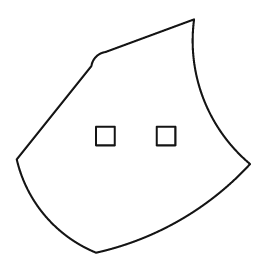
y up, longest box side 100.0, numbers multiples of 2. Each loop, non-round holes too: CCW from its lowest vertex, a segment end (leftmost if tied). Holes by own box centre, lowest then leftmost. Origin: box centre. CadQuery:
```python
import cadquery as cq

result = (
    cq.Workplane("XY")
    .moveTo(-16.0, -50.0)
    .threePointArc((20.0, -36.0), (50.0, -12.0))
    .threePointArc((30.0, 16.0), (26.0, 50.0))
    .lineTo(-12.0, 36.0)
    .threePointArc((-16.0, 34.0), (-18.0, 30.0))
    .lineTo(-50.0, -10.0)
    .threePointArc((-38.0, -34.0), (-16.0, -50.0))
    .close()
    .moveTo(-16.0, -4.0)
    .lineTo(-8.0, -4.0)
    .lineTo(-8.0, 4.0)
    .lineTo(-16.0, 4.0)
    .close()
    .moveTo(10.0, -4.0)
    .lineTo(18.0, -4.0)
    .lineTo(18.0, 4.0)
    .lineTo(10.0, 4.0)
    .close()
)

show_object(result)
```